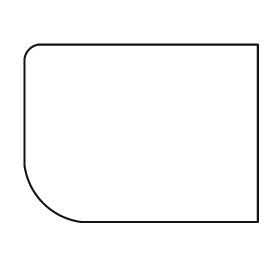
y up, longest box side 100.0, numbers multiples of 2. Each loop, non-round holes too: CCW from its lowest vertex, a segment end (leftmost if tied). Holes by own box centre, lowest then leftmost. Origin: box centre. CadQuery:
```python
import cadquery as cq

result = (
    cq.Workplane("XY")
    .moveTo(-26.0, -38.0)
    .lineTo(50.0, -38.0)
    .lineTo(50.0, 38.0)
    .lineTo(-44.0, 38.0)
    .threePointArc((-48.0, 36.0), (-50.0, 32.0))
    .lineTo(-50.0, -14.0)
    .threePointArc((-42.0, -30.0), (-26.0, -38.0))
    .close()
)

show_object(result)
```